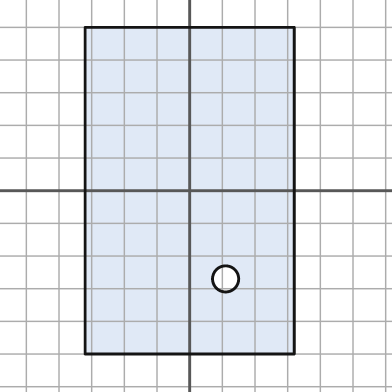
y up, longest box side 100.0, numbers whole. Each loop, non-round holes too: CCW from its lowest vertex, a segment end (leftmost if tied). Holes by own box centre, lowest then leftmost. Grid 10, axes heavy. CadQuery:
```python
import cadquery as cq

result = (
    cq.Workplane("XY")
    .moveTo(-32.0, -50.0)
    .lineTo(32.0, -50.0)
    .lineTo(32.0, 50.0)
    .lineTo(-32.0, 50.0)
    .close()
    .moveTo(11.0, -27.0)
    .circle(4.0)
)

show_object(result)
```